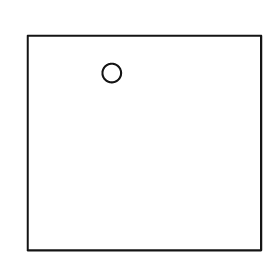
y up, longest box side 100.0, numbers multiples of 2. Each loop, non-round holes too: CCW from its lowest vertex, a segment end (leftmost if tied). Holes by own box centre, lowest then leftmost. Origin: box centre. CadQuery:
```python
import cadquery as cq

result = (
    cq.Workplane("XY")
    .moveTo(-50.0, -46.0)
    .lineTo(50.0, -46.0)
    .lineTo(50.0, 46.0)
    .lineTo(-50.0, 46.0)
    .close()
    .moveTo(-14.0, 30.0)
    .circle(4.0)
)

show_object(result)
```